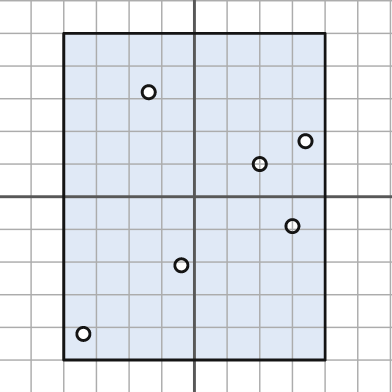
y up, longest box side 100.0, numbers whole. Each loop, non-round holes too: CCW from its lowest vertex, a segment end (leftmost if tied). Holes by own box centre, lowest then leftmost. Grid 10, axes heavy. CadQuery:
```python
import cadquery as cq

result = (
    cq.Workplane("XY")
    .moveTo(-40.0, -50.0)
    .lineTo(40.0, -50.0)
    .lineTo(40.0, 50.0)
    .lineTo(-40.0, 50.0)
    .close()
    .moveTo(-34.0, -42.0)
    .circle(2.0)
    .moveTo(-4.0, -21.0)
    .circle(2.0)
    .moveTo(30.0, -9.0)
    .circle(2.0)
    .moveTo(20.0, 10.0)
    .circle(2.0)
    .moveTo(34.0, 17.0)
    .circle(2.0)
    .moveTo(-14.0, 32.0)
    .circle(2.0)
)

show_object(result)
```